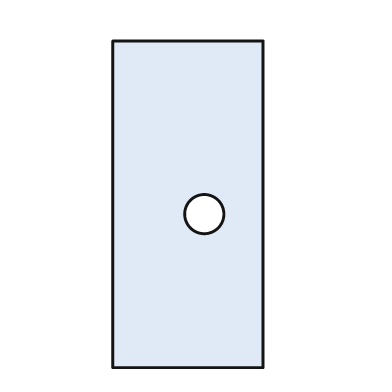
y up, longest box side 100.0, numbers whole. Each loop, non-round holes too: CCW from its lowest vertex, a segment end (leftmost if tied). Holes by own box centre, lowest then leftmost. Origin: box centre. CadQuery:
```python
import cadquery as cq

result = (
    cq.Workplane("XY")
    .moveTo(-23.0, -50.0)
    .lineTo(23.0, -50.0)
    .lineTo(23.0, 50.0)
    .lineTo(-23.0, 50.0)
    .close()
    .moveTo(5.0, -3.0)
    .circle(6.0)
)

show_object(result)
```